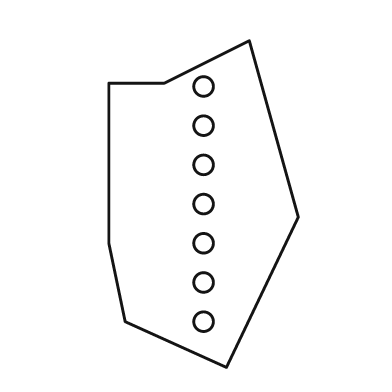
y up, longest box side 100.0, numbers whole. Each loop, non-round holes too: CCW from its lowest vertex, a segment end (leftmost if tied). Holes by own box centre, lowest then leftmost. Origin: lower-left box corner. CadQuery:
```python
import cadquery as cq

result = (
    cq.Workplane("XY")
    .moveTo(36.0, 0.0)
    .lineTo(58.0, 46.0)
    .lineTo(43.0, 100.0)
    .lineTo(17.0, 87.0)
    .lineTo(0.0, 87.0)
    .lineTo(0.0, 38.0)
    .lineTo(5.0, 14.0)
    .close()
    .moveTo(29.0, 14.0)
    .circle(3.0)
    .moveTo(29.0, 26.0)
    .circle(3.0)
    .moveTo(29.0, 38.0)
    .circle(3.0)
    .moveTo(29.0, 50.0)
    .circle(3.0)
    .moveTo(29.0, 62.0)
    .circle(3.0)
    .moveTo(29.0, 74.0)
    .circle(3.0)
    .moveTo(29.0, 86.0)
    .circle(3.0)
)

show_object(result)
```